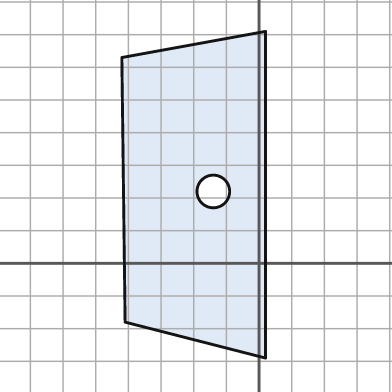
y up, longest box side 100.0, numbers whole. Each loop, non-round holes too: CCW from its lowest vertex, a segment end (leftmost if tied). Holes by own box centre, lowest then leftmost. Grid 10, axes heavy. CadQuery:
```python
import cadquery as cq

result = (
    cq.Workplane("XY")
    .moveTo(2.0, -29.0)
    .lineTo(2.0, 71.0)
    .lineTo(-42.0, 63.0)
    .lineTo(-41.0, -18.0)
    .close()
    .moveTo(-14.0, 22.0)
    .circle(5.0)
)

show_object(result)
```